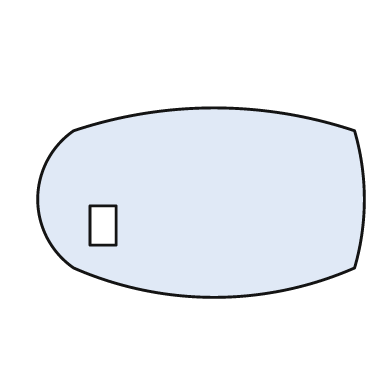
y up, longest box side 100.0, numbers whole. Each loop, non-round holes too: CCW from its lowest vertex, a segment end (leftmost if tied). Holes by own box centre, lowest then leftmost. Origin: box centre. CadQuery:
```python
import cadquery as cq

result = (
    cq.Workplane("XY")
    .moveTo(-39.0, -20.0)
    .threePointArc((4.0, -29.0), (47.0, -20.0))
    .threePointArc((50.0, 1.0), (47.0, 22.0))
    .threePointArc((4.0, 29.0), (-39.0, 22.0))
    .threePointArc((-50.0, 1.0), (-39.0, -20.0))
    .close()
    .moveTo(-34.0, -13.0)
    .lineTo(-26.0, -13.0)
    .lineTo(-26.0, -1.0)
    .lineTo(-34.0, -1.0)
    .close()
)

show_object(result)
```